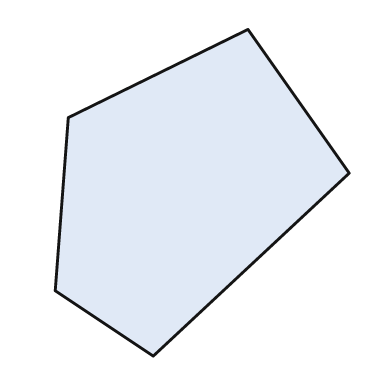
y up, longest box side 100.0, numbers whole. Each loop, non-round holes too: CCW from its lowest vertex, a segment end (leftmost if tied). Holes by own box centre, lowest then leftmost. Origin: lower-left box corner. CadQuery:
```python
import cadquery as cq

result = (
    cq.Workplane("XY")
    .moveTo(30.0, 0.0)
    .lineTo(90.0, 56.0)
    .lineTo(59.0, 100.0)
    .lineTo(4.0, 73.0)
    .lineTo(0.0, 20.0)
    .close()
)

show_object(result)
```